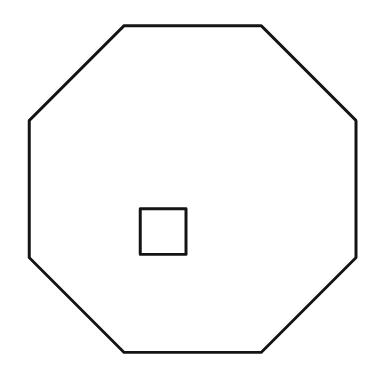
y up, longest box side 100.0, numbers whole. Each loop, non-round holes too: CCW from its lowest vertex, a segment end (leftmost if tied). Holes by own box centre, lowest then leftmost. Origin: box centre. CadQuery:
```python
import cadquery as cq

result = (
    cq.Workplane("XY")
    .moveTo(-21.0, -50.0)
    .lineTo(21.0, -50.0)
    .lineTo(50.0, -21.0)
    .lineTo(50.0, 21.0)
    .lineTo(21.0, 50.0)
    .lineTo(-21.0, 50.0)
    .lineTo(-50.0, 21.0)
    .lineTo(-50.0, -21.0)
    .close()
    .moveTo(-16.0, -20.0)
    .lineTo(-2.0, -20.0)
    .lineTo(-2.0, -6.0)
    .lineTo(-16.0, -6.0)
    .close()
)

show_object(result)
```